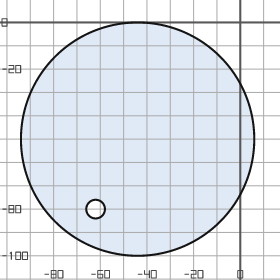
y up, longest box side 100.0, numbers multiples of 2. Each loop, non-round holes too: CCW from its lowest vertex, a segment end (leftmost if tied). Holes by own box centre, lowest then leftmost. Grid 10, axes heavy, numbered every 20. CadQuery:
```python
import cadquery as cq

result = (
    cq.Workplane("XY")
    .moveTo(-44.0, -50.0)
    .circle(50.0)
    .moveTo(-62.0, -80.0)
    .circle(4.0)
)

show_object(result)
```